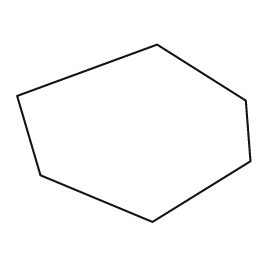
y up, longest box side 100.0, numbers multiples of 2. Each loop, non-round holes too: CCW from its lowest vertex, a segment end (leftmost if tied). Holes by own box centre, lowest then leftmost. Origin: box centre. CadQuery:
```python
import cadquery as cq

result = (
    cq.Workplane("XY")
    .moveTo(8.0, -38.0)
    .lineTo(50.0, -12.0)
    .lineTo(48.0, 14.0)
    .lineTo(10.0, 38.0)
    .lineTo(-50.0, 16.0)
    .lineTo(-40.0, -18.0)
    .close()
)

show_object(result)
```